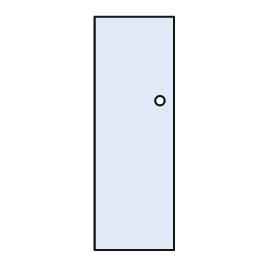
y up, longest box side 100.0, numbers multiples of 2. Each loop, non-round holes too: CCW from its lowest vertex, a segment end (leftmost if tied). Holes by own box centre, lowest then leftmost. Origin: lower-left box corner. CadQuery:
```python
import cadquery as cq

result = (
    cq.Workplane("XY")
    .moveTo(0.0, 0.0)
    .lineTo(34.0, 0.0)
    .lineTo(34.0, 100.0)
    .lineTo(0.0, 100.0)
    .close()
    .moveTo(28.0, 64.0)
    .circle(2.0)
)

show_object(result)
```